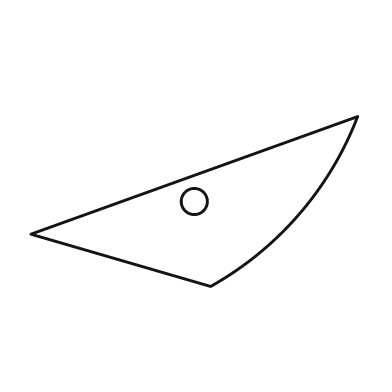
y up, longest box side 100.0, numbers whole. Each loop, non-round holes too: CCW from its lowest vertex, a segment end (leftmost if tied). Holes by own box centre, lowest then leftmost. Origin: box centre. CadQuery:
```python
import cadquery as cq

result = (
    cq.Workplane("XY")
    .moveTo(5.0, -26.0)
    .threePointArc((32.0, -4.0), (50.0, 26.0))
    .lineTo(-50.0, -10.0)
    .close()
    .moveTo(0.0, 0.0)
    .circle(4.0)
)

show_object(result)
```